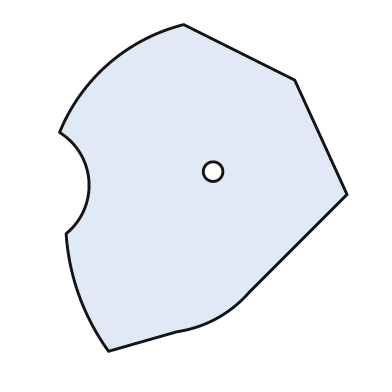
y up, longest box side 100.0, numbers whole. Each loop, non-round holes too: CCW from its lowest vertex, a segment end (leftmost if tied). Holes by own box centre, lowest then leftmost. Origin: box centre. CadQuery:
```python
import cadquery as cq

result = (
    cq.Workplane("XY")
    .moveTo(-29.0, -50.0)
    .lineTo(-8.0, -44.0)
    .threePointArc((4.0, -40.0), (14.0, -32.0))
    .lineTo(44.0, -2.0)
    .lineTo(28.0, 33.0)
    .lineTo(-6.0, 50.0)
    .threePointArc((-29.0, 38.0), (-44.0, 17.0))
    .threePointArc((-35.0, 2.0), (-42.0, -14.0))
    .threePointArc((-38.0, -33.0), (-29.0, -50.0))
    .close()
    .moveTo(3.0, 5.0)
    .circle(3.0)
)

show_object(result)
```